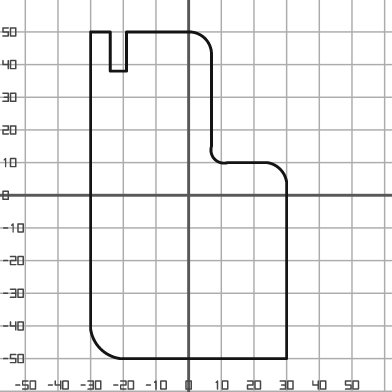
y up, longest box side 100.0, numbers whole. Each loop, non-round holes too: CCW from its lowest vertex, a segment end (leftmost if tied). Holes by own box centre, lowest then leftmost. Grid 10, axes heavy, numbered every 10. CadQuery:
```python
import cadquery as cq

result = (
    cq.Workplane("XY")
    .moveTo(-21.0, -50.0)
    .lineTo(30.0, -50.0)
    .lineTo(30.0, 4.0)
    .threePointArc((28.0, 8.0), (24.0, 10.0))
    .lineTo(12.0, 10.0)
    .threePointArc((8.0, 11.0), (7.0, 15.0))
    .lineTo(7.0, 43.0)
    .threePointArc((5.0, 48.0), (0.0, 50.0))
    .lineTo(-19.0, 50.0)
    .lineTo(-19.0, 38.0)
    .lineTo(-24.0, 38.0)
    .lineTo(-24.0, 50.0)
    .lineTo(-30.0, 50.0)
    .lineTo(-30.0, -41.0)
    .threePointArc((-27.0, -47.0), (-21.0, -50.0))
    .close()
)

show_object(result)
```